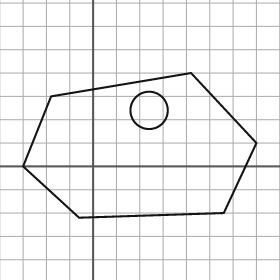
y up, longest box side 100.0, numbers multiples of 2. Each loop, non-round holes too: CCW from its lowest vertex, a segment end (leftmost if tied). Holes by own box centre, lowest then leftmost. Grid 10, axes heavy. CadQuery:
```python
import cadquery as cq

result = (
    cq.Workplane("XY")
    .moveTo(-6.0, -22.0)
    .lineTo(56.0, -20.0)
    .lineTo(70.0, 10.0)
    .lineTo(42.0, 40.0)
    .lineTo(-18.0, 30.0)
    .lineTo(-30.0, 0.0)
    .close()
    .moveTo(24.0, 24.0)
    .circle(8.0)
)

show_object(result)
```